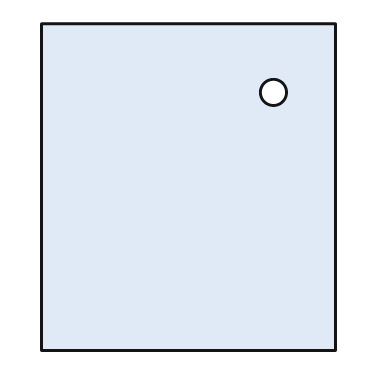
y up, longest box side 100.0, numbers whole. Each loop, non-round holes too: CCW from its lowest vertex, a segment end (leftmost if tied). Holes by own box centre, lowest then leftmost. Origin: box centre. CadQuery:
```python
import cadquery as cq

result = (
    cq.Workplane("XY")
    .moveTo(-45.0, -50.0)
    .lineTo(45.0, -50.0)
    .lineTo(45.0, 50.0)
    .lineTo(-45.0, 50.0)
    .close()
    .moveTo(26.0, 29.0)
    .circle(4.0)
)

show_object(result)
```